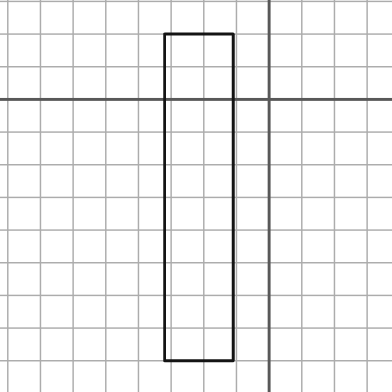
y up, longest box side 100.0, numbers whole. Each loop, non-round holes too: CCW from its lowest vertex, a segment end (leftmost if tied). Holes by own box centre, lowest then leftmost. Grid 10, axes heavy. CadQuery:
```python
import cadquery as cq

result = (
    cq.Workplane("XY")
    .moveTo(-32.0, -80.0)
    .lineTo(-11.0, -80.0)
    .lineTo(-11.0, 20.0)
    .lineTo(-32.0, 20.0)
    .close()
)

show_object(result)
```